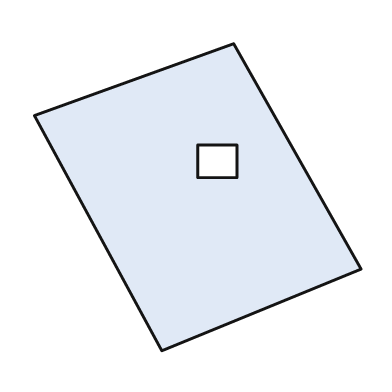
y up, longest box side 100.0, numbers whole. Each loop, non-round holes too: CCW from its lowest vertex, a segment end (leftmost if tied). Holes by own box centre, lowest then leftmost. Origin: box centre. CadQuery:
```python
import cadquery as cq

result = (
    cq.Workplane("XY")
    .moveTo(-11.0, -47.0)
    .lineTo(50.0, -22.0)
    .lineTo(11.0, 47.0)
    .lineTo(-50.0, 25.0)
    .close()
    .moveTo(0.0, 6.0)
    .lineTo(12.0, 6.0)
    .lineTo(12.0, 16.0)
    .lineTo(0.0, 16.0)
    .close()
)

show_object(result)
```